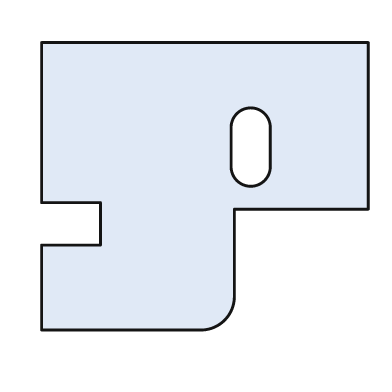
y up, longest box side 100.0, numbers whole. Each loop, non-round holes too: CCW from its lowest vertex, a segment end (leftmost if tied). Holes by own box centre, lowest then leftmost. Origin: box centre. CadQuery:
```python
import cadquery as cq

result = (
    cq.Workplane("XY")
    .moveTo(-50.0, -44.0)
    .lineTo(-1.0, -44.0)
    .threePointArc((6.0, -41.0), (9.0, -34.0))
    .lineTo(9.0, -7.0)
    .lineTo(50.0, -7.0)
    .lineTo(50.0, 44.0)
    .lineTo(-50.0, 44.0)
    .lineTo(-50.0, -5.0)
    .lineTo(-32.0, -5.0)
    .lineTo(-32.0, -18.0)
    .lineTo(-50.0, -18.0)
    .close()
    .moveTo(8.0, 6.0)
    .threePointArc((14.0, 0.0), (20.0, 6.0))
    .lineTo(20.0, 18.0)
    .threePointArc((14.0, 24.0), (8.0, 18.0))
    .close()
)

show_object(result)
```